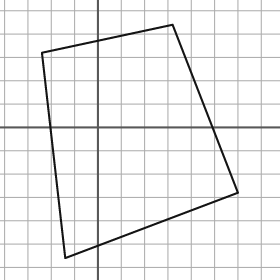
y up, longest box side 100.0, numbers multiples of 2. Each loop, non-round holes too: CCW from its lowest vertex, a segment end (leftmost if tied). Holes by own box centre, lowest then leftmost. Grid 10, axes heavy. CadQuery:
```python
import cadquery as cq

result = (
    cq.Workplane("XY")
    .moveTo(-14.0, -56.0)
    .lineTo(60.0, -28.0)
    .lineTo(32.0, 44.0)
    .lineTo(-24.0, 32.0)
    .close()
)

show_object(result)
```